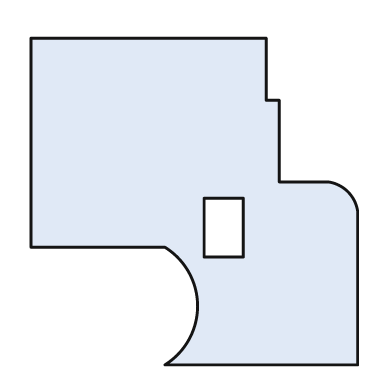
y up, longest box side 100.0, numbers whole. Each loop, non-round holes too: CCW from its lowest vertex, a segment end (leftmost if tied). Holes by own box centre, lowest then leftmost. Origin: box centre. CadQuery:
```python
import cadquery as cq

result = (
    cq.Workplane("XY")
    .moveTo(-9.0, -50.0)
    .lineTo(50.0, -50.0)
    .lineTo(50.0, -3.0)
    .threePointArc((47.0, 3.0), (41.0, 6.0))
    .lineTo(26.0, 6.0)
    .lineTo(26.0, 31.0)
    .lineTo(22.0, 31.0)
    .lineTo(22.0, 50.0)
    .lineTo(-50.0, 50.0)
    .lineTo(-50.0, -14.0)
    .lineTo(-9.0, -14.0)
    .threePointArc((1.0, -32.0), (-9.0, -50.0))
    .close()
    .moveTo(3.0, -17.0)
    .lineTo(15.0, -17.0)
    .lineTo(15.0, 1.0)
    .lineTo(3.0, 1.0)
    .close()
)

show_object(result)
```